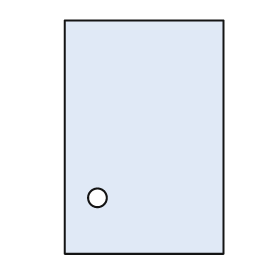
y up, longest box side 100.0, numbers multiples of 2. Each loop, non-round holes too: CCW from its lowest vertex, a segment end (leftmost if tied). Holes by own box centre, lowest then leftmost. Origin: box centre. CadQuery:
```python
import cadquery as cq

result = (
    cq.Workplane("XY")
    .moveTo(-34.0, -50.0)
    .lineTo(34.0, -50.0)
    .lineTo(34.0, 50.0)
    .lineTo(-34.0, 50.0)
    .close()
    .moveTo(-20.0, -26.0)
    .circle(4.0)
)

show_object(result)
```